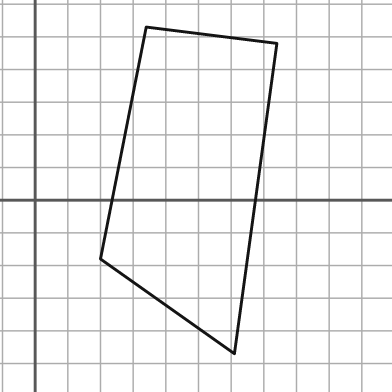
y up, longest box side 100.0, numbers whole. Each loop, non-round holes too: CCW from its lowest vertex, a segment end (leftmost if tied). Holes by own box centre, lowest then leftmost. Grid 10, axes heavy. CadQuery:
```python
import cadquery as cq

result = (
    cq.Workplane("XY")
    .moveTo(61.0, -47.0)
    .lineTo(74.0, 48.0)
    .lineTo(34.0, 53.0)
    .lineTo(20.0, -18.0)
    .close()
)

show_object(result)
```